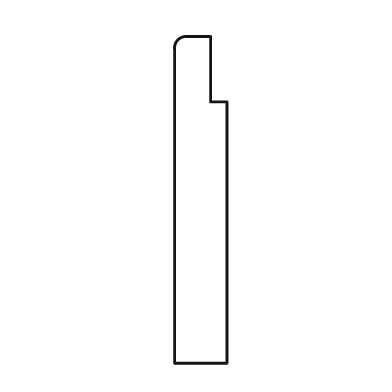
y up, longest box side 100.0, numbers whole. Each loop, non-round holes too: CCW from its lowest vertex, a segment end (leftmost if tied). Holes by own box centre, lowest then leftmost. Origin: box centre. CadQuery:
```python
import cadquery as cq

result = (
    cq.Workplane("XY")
    .moveTo(-8.0, -50.0)
    .lineTo(8.0, -50.0)
    .lineTo(8.0, 30.0)
    .lineTo(3.0, 30.0)
    .lineTo(3.0, 50.0)
    .lineTo(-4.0, 50.0)
    .threePointArc((-7.0, 49.0), (-8.0, 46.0))
    .close()
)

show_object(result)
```